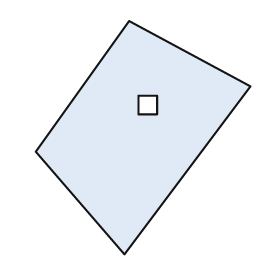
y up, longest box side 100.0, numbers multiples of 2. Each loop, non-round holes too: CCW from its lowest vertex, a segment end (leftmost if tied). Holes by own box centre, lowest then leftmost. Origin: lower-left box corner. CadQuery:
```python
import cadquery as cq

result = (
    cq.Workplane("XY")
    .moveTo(38.0, 0.0)
    .lineTo(92.0, 72.0)
    .lineTo(40.0, 100.0)
    .lineTo(0.0, 44.0)
    .close()
    .moveTo(44.0, 60.0)
    .lineTo(52.0, 60.0)
    .lineTo(52.0, 68.0)
    .lineTo(44.0, 68.0)
    .close()
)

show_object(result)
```